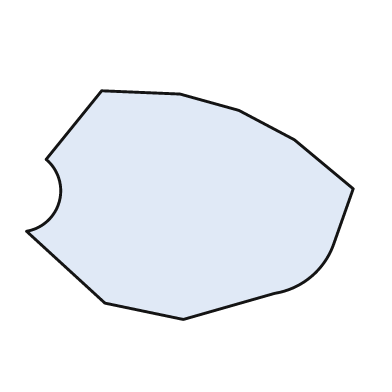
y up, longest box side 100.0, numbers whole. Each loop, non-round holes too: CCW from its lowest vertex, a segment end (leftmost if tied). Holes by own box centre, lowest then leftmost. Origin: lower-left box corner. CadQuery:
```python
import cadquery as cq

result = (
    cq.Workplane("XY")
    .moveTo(48.0, 0.0)
    .lineTo(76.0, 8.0)
    .threePointArc((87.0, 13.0), (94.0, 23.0))
    .lineTo(100.0, 40.0)
    .lineTo(82.0, 55.0)
    .lineTo(65.0, 64.0)
    .lineTo(47.0, 69.0)
    .lineTo(23.0, 70.0)
    .lineTo(6.0, 49.0)
    .threePointArc((10.0, 36.0), (0.0, 27.0))
    .lineTo(24.0, 5.0)
    .close()
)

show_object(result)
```